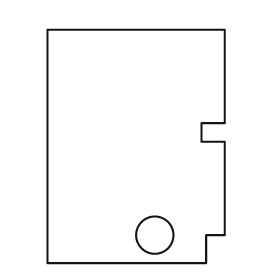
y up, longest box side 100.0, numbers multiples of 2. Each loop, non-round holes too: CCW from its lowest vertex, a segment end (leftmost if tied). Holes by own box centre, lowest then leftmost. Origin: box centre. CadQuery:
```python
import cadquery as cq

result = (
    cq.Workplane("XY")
    .moveTo(-38.0, -50.0)
    .lineTo(30.0, -50.0)
    .lineTo(30.0, -38.0)
    .lineTo(38.0, -38.0)
    .lineTo(38.0, 2.0)
    .lineTo(28.0, 2.0)
    .lineTo(28.0, 10.0)
    .lineTo(38.0, 10.0)
    .lineTo(38.0, 50.0)
    .lineTo(-38.0, 50.0)
    .close()
    .moveTo(8.0, -38.0)
    .circle(8.0)
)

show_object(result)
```